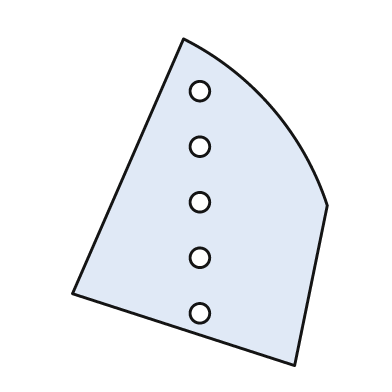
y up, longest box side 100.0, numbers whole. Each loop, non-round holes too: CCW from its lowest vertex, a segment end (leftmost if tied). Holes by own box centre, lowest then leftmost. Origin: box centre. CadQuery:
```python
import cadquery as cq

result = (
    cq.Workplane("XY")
    .moveTo(29.0, -50.0)
    .lineTo(39.0, -1.0)
    .threePointArc((22.0, 29.0), (-5.0, 50.0))
    .lineTo(-39.0, -28.0)
    .close()
    .moveTo(0.0, -34.0)
    .circle(3.0)
    .moveTo(0.0, -17.0)
    .circle(3.0)
    .moveTo(0.0, 0.0)
    .circle(3.0)
    .moveTo(0.0, 17.0)
    .circle(3.0)
    .moveTo(0.0, 34.0)
    .circle(3.0)
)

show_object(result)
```